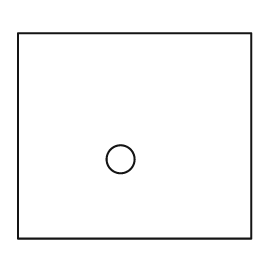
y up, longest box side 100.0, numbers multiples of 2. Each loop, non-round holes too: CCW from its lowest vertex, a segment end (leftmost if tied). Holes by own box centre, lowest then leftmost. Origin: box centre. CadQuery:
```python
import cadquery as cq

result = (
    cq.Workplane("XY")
    .moveTo(-50.0, -44.0)
    .lineTo(50.0, -44.0)
    .lineTo(50.0, 44.0)
    .lineTo(-50.0, 44.0)
    .close()
    .moveTo(-6.0, -10.0)
    .circle(6.0)
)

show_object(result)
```